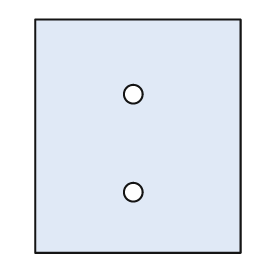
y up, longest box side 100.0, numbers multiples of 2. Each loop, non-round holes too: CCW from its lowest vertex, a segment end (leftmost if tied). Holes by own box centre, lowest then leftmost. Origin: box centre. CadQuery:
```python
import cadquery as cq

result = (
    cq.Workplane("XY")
    .moveTo(-44.0, -50.0)
    .lineTo(44.0, -50.0)
    .lineTo(44.0, 50.0)
    .lineTo(-44.0, 50.0)
    .close()
    .moveTo(-2.0, -24.0)
    .circle(4.0)
    .moveTo(-2.0, 18.0)
    .circle(4.0)
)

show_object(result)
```